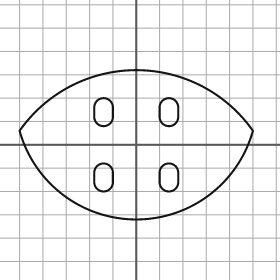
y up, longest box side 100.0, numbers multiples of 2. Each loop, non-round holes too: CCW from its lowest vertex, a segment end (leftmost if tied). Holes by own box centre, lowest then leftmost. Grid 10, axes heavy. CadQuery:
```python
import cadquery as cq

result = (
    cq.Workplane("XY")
    .moveTo(-50.0, 6.0)
    .threePointArc((0.0, -32.0), (50.0, 6.0))
    .threePointArc((0.0, 32.0), (-50.0, 6.0))
    .close()
    .moveTo(-18.0, -16.0)
    .threePointArc((-14.0, -20.0), (-10.0, -16.0))
    .lineTo(-10.0, -12.0)
    .threePointArc((-14.0, -8.0), (-18.0, -12.0))
    .close()
    .moveTo(10.0, -16.0)
    .threePointArc((14.0, -20.0), (18.0, -16.0))
    .lineTo(18.0, -12.0)
    .threePointArc((14.0, -8.0), (10.0, -12.0))
    .close()
    .moveTo(-18.0, 12.0)
    .threePointArc((-14.0, 8.0), (-10.0, 12.0))
    .lineTo(-10.0, 16.0)
    .threePointArc((-14.0, 20.0), (-18.0, 16.0))
    .close()
    .moveTo(10.0, 12.0)
    .threePointArc((14.0, 8.0), (18.0, 12.0))
    .lineTo(18.0, 16.0)
    .threePointArc((14.0, 20.0), (10.0, 16.0))
    .close()
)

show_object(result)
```